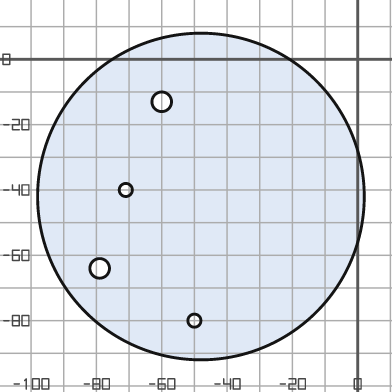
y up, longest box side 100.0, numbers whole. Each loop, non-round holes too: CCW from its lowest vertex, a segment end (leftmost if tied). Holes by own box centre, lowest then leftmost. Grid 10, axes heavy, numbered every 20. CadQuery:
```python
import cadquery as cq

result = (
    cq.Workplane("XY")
    .moveTo(-48.0, -42.0)
    .circle(50.0)
    .moveTo(-50.0, -80.0)
    .circle(2.0)
    .moveTo(-79.0, -64.0)
    .circle(3.0)
    .moveTo(-71.0, -40.0)
    .circle(2.0)
    .moveTo(-60.0, -13.0)
    .circle(3.0)
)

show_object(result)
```